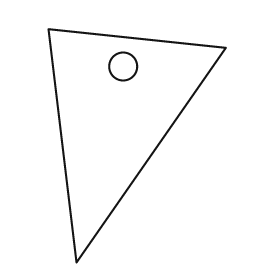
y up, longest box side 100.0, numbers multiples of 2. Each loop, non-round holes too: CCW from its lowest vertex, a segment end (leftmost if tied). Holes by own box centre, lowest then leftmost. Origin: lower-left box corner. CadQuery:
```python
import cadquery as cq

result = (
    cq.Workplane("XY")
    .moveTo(12.0, 0.0)
    .lineTo(76.0, 92.0)
    .lineTo(0.0, 100.0)
    .close()
    .moveTo(32.0, 84.0)
    .circle(6.0)
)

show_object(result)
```